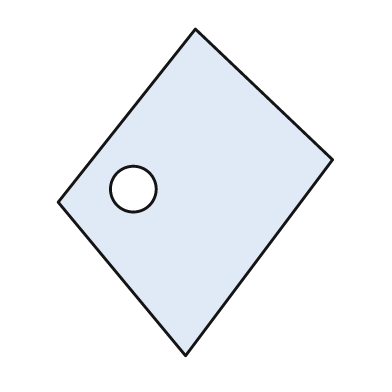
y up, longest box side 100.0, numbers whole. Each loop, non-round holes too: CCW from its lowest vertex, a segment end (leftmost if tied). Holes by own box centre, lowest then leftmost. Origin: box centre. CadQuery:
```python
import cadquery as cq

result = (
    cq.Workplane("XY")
    .moveTo(-3.0, -50.0)
    .lineTo(42.0, 10.0)
    .lineTo(0.0, 50.0)
    .lineTo(-42.0, -3.0)
    .close()
    .moveTo(-19.0, 1.0)
    .circle(7.0)
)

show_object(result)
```